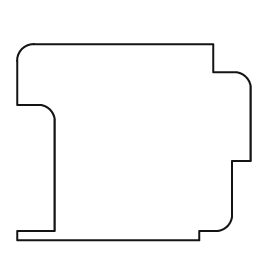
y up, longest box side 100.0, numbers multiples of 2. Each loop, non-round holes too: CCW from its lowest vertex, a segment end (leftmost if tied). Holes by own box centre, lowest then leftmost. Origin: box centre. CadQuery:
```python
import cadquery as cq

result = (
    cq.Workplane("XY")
    .moveTo(-50.0, -42.0)
    .lineTo(28.0, -42.0)
    .lineTo(28.0, -38.0)
    .lineTo(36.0, -38.0)
    .threePointArc((40.0, -36.0), (42.0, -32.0))
    .lineTo(42.0, -8.0)
    .lineTo(50.0, -8.0)
    .lineTo(50.0, 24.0)
    .threePointArc((48.0, 28.0), (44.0, 30.0))
    .lineTo(34.0, 30.0)
    .lineTo(34.0, 42.0)
    .lineTo(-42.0, 42.0)
    .threePointArc((-48.0, 40.0), (-50.0, 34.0))
    .lineTo(-50.0, 16.0)
    .lineTo(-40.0, 16.0)
    .threePointArc((-36.0, 14.0), (-34.0, 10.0))
    .lineTo(-34.0, -38.0)
    .lineTo(-50.0, -38.0)
    .close()
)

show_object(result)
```